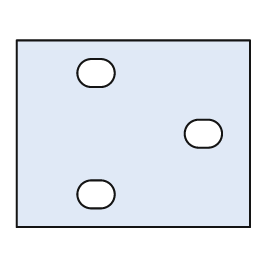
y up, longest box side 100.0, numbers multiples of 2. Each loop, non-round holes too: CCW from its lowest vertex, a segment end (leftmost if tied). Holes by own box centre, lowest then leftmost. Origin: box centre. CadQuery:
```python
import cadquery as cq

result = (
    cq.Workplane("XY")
    .moveTo(-50.0, -40.0)
    .lineTo(50.0, -40.0)
    .lineTo(50.0, 40.0)
    .lineTo(-50.0, 40.0)
    .close()
    .moveTo(-18.0, -32.0)
    .lineTo(-14.0, -32.0)
    .threePointArc((-8.0, -26.0), (-14.0, -20.0))
    .lineTo(-18.0, -20.0)
    .threePointArc((-24.0, -26.0), (-18.0, -32.0))
    .close()
    .moveTo(28.0, -6.0)
    .lineTo(32.0, -6.0)
    .threePointArc((38.0, 0.0), (32.0, 6.0))
    .lineTo(28.0, 6.0)
    .threePointArc((22.0, 0.0), (28.0, -6.0))
    .close()
    .moveTo(-18.0, 20.0)
    .lineTo(-14.0, 20.0)
    .threePointArc((-8.0, 26.0), (-14.0, 32.0))
    .lineTo(-18.0, 32.0)
    .threePointArc((-24.0, 26.0), (-18.0, 20.0))
    .close()
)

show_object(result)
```